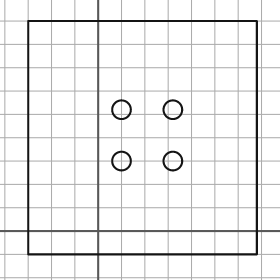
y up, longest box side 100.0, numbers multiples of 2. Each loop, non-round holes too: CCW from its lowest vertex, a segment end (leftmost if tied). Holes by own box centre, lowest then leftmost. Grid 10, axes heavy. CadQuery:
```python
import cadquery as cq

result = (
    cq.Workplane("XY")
    .moveTo(-30.0, -10.0)
    .lineTo(68.0, -10.0)
    .lineTo(68.0, 90.0)
    .lineTo(-30.0, 90.0)
    .close()
    .moveTo(10.0, 30.0)
    .circle(4.0)
    .moveTo(32.0, 30.0)
    .circle(4.0)
    .moveTo(10.0, 52.0)
    .circle(4.0)
    .moveTo(32.0, 52.0)
    .circle(4.0)
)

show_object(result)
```